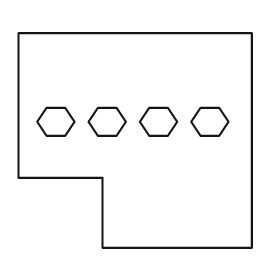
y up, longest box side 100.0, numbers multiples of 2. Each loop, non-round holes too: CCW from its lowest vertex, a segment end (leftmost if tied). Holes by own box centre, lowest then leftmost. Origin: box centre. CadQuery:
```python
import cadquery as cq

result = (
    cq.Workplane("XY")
    .moveTo(-14.0, -46.0)
    .lineTo(50.0, -46.0)
    .lineTo(50.0, 46.0)
    .lineTo(-50.0, 46.0)
    .lineTo(-50.0, -16.0)
    .lineTo(-14.0, -16.0)
    .close()
    .moveTo(-38.0, 2.0)
    .lineTo(-30.0, 2.0)
    .lineTo(-26.0, 8.0)
    .lineTo(-30.0, 14.0)
    .lineTo(-38.0, 14.0)
    .lineTo(-42.0, 8.0)
    .close()
    .moveTo(-16.0, 2.0)
    .lineTo(-8.0, 2.0)
    .lineTo(-4.0, 8.0)
    .lineTo(-8.0, 14.0)
    .lineTo(-16.0, 14.0)
    .lineTo(-20.0, 8.0)
    .close()
    .moveTo(6.0, 2.0)
    .lineTo(14.0, 2.0)
    .lineTo(18.0, 8.0)
    .lineTo(14.0, 14.0)
    .lineTo(6.0, 14.0)
    .lineTo(2.0, 8.0)
    .close()
    .moveTo(28.0, 2.0)
    .lineTo(36.0, 2.0)
    .lineTo(40.0, 8.0)
    .lineTo(36.0, 14.0)
    .lineTo(28.0, 14.0)
    .lineTo(24.0, 8.0)
    .close()
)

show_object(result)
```